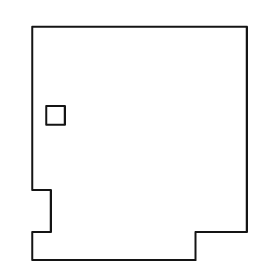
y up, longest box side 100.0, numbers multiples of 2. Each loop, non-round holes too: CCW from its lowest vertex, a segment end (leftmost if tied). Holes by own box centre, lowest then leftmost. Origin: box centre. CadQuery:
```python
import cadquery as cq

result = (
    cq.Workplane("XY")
    .moveTo(-46.0, -50.0)
    .lineTo(24.0, -50.0)
    .lineTo(24.0, -38.0)
    .lineTo(46.0, -38.0)
    .lineTo(46.0, 50.0)
    .lineTo(-46.0, 50.0)
    .lineTo(-46.0, -20.0)
    .lineTo(-38.0, -20.0)
    .lineTo(-38.0, -38.0)
    .lineTo(-46.0, -38.0)
    .close()
    .moveTo(-40.0, 8.0)
    .lineTo(-32.0, 8.0)
    .lineTo(-32.0, 16.0)
    .lineTo(-40.0, 16.0)
    .close()
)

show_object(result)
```